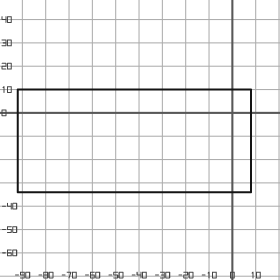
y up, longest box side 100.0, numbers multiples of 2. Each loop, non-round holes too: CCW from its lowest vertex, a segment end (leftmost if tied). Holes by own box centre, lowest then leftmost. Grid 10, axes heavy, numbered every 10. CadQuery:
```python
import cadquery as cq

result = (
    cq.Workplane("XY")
    .moveTo(-92.0, -34.0)
    .lineTo(8.0, -34.0)
    .lineTo(8.0, 10.0)
    .lineTo(-92.0, 10.0)
    .close()
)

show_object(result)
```